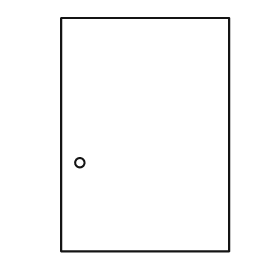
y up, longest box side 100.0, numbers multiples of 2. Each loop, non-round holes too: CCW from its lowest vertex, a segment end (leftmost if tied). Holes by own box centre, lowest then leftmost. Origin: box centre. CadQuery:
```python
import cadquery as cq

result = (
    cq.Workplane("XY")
    .moveTo(-36.0, -50.0)
    .lineTo(36.0, -50.0)
    .lineTo(36.0, 50.0)
    .lineTo(-36.0, 50.0)
    .close()
    .moveTo(-28.0, -12.0)
    .circle(2.0)
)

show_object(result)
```